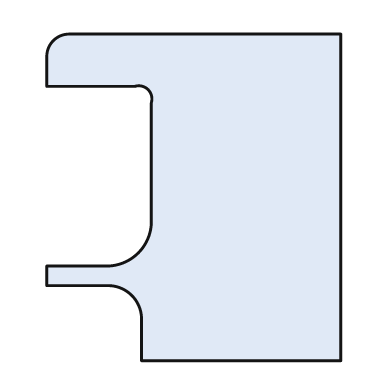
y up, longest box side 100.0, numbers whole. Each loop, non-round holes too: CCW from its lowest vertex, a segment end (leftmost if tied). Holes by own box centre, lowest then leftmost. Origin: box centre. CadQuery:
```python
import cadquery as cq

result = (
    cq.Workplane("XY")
    .moveTo(-16.0, -50.0)
    .lineTo(45.0, -50.0)
    .lineTo(45.0, 50.0)
    .lineTo(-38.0, 50.0)
    .threePointArc((-43.0, 48.0), (-45.0, 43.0))
    .lineTo(-45.0, 34.0)
    .lineTo(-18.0, 34.0)
    .threePointArc((-14.0, 33.0), (-13.0, 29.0))
    .lineTo(-13.0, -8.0)
    .threePointArc((-17.0, -17.0), (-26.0, -21.0))
    .lineTo(-45.0, -21.0)
    .lineTo(-45.0, -27.0)
    .lineTo(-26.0, -27.0)
    .threePointArc((-19.0, -30.0), (-16.0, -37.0))
    .close()
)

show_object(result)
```